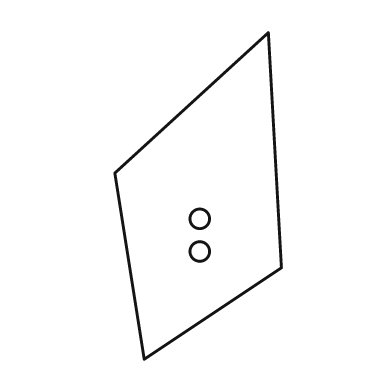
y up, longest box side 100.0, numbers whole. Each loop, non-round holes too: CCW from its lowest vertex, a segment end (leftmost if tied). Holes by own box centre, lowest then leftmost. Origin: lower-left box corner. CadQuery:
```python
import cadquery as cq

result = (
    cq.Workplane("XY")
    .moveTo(9.0, 0.0)
    .lineTo(51.0, 28.0)
    .lineTo(47.0, 100.0)
    .lineTo(0.0, 57.0)
    .close()
    .moveTo(26.0, 33.0)
    .circle(3.0)
    .moveTo(26.0, 43.0)
    .circle(3.0)
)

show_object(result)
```